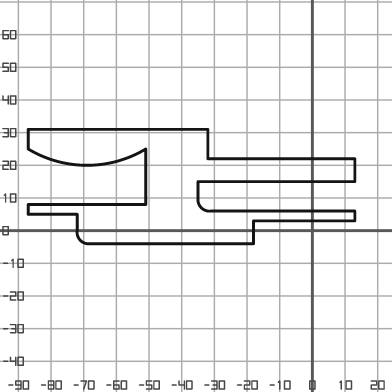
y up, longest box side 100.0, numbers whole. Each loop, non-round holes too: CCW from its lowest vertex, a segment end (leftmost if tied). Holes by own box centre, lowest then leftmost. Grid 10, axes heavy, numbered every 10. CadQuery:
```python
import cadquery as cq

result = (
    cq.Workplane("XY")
    .moveTo(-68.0, -4.0)
    .lineTo(-18.0, -4.0)
    .lineTo(-18.0, 3.0)
    .lineTo(13.0, 3.0)
    .lineTo(13.0, 6.0)
    .lineTo(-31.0, 6.0)
    .threePointArc((-34.0, 7.0), (-35.0, 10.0))
    .lineTo(-35.0, 15.0)
    .lineTo(13.0, 15.0)
    .lineTo(13.0, 22.0)
    .lineTo(-32.0, 22.0)
    .lineTo(-32.0, 31.0)
    .lineTo(-87.0, 31.0)
    .lineTo(-87.0, 25.0)
    .threePointArc((-69.0, 20.0), (-51.0, 25.0))
    .lineTo(-51.0, 8.0)
    .lineTo(-87.0, 8.0)
    .lineTo(-87.0, 5.0)
    .lineTo(-72.0, 5.0)
    .lineTo(-72.0, 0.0)
    .threePointArc((-71.0, -3.0), (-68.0, -4.0))
    .close()
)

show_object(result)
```